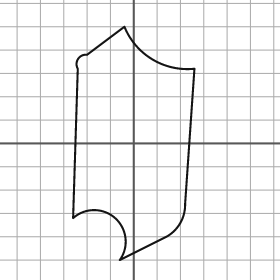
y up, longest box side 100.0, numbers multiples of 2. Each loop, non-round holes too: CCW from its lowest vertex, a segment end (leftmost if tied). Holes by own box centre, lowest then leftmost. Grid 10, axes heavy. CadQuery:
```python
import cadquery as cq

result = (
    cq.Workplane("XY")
    .moveTo(-6.0, -50.0)
    .lineTo(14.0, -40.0)
    .threePointArc((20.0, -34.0), (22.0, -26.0))
    .lineTo(26.0, 32.0)
    .threePointArc((8.0, 36.0), (-4.0, 50.0))
    .lineTo(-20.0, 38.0)
    .threePointArc((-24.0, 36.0), (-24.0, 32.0))
    .lineTo(-26.0, -32.0)
    .threePointArc((-8.0, -32.0), (-6.0, -50.0))
    .close()
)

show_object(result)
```